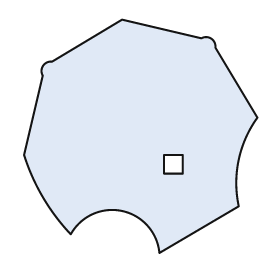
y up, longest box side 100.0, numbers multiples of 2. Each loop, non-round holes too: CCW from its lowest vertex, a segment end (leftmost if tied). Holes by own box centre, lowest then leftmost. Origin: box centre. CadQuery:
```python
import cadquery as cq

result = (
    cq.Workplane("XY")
    .moveTo(8.0, -50.0)
    .lineTo(42.0, -30.0)
    .threePointArc((42.0, -10.0), (50.0, 8.0))
    .lineTo(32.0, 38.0)
    .threePointArc((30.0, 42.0), (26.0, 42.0))
    .lineTo(-8.0, 50.0)
    .lineTo(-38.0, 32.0)
    .threePointArc((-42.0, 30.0), (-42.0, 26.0))
    .lineTo(-50.0, -8.0)
    .threePointArc((-42.0, -26.0), (-30.0, -42.0))
    .threePointArc((-8.0, -32.0), (8.0, -50.0))
    .close()
    .moveTo(10.0, -16.0)
    .lineTo(18.0, -16.0)
    .lineTo(18.0, -8.0)
    .lineTo(10.0, -8.0)
    .close()
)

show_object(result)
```